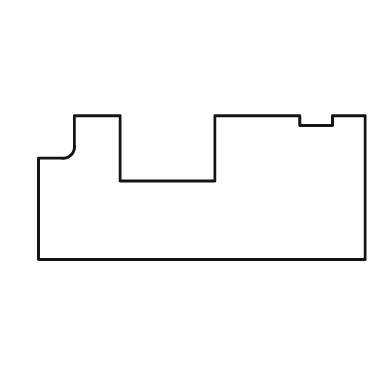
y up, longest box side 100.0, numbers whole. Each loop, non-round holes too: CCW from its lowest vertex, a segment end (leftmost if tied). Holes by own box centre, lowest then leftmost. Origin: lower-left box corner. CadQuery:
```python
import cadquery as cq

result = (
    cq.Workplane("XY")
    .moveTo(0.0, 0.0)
    .lineTo(100.0, 0.0)
    .lineTo(100.0, 44.0)
    .lineTo(90.0, 44.0)
    .lineTo(90.0, 41.0)
    .lineTo(80.0, 41.0)
    .lineTo(80.0, 44.0)
    .lineTo(54.0, 44.0)
    .lineTo(54.0, 24.0)
    .lineTo(25.0, 24.0)
    .lineTo(25.0, 44.0)
    .lineTo(11.0, 44.0)
    .lineTo(11.0, 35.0)
    .threePointArc((10.0, 32.0), (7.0, 31.0))
    .lineTo(0.0, 31.0)
    .close()
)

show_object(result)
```